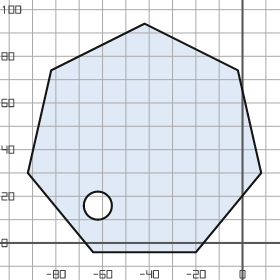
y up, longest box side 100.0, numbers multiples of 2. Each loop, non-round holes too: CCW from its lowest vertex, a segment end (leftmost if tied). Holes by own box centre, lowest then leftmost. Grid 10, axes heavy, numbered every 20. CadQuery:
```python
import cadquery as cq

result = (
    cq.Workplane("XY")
    .moveTo(-64.0, -4.0)
    .lineTo(-20.0, -4.0)
    .lineTo(8.0, 30.0)
    .lineTo(-2.0, 74.0)
    .lineTo(-42.0, 94.0)
    .lineTo(-82.0, 74.0)
    .lineTo(-92.0, 30.0)
    .close()
    .moveTo(-62.0, 16.0)
    .circle(6.0)
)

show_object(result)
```